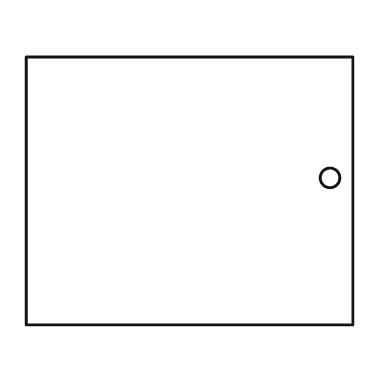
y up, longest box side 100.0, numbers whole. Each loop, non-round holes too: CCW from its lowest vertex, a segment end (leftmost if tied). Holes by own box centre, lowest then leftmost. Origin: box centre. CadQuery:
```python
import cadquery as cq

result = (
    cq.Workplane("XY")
    .moveTo(-50.0, -41.0)
    .lineTo(50.0, -41.0)
    .lineTo(50.0, 41.0)
    .lineTo(-50.0, 41.0)
    .close()
    .moveTo(43.0, 4.0)
    .circle(3.0)
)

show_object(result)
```